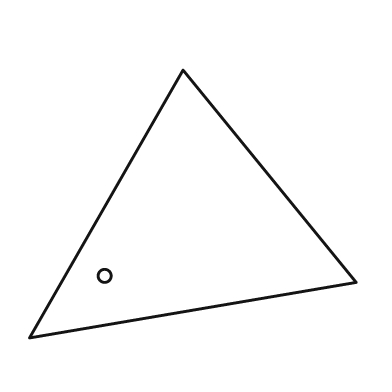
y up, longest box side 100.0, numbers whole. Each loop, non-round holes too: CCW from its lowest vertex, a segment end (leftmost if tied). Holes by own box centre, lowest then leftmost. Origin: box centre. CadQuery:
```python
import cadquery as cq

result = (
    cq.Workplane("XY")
    .moveTo(-50.0, -41.0)
    .lineTo(50.0, -24.0)
    .lineTo(-3.0, 41.0)
    .close()
    .moveTo(-27.0, -22.0)
    .circle(2.0)
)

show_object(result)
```